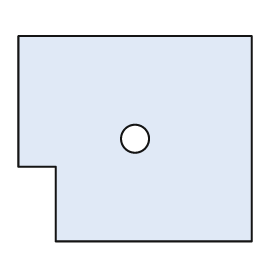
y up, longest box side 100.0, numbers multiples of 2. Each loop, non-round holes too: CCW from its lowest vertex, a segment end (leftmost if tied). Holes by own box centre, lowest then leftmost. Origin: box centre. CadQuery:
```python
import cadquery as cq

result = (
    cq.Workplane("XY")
    .moveTo(-34.0, -44.0)
    .lineTo(50.0, -44.0)
    .lineTo(50.0, 44.0)
    .lineTo(-50.0, 44.0)
    .lineTo(-50.0, -12.0)
    .lineTo(-34.0, -12.0)
    .close()
    .moveTo(0.0, 0.0)
    .circle(6.0)
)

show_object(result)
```